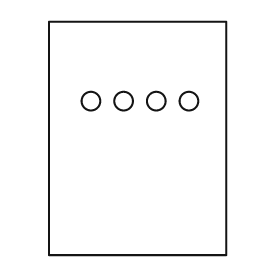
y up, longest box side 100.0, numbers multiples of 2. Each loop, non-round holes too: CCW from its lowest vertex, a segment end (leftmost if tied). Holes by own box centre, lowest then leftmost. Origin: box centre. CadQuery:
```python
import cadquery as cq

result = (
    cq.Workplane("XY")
    .moveTo(-38.0, -50.0)
    .lineTo(38.0, -50.0)
    .lineTo(38.0, 50.0)
    .lineTo(-38.0, 50.0)
    .close()
    .moveTo(-20.0, 16.0)
    .circle(4.0)
    .moveTo(-6.0, 16.0)
    .circle(4.0)
    .moveTo(8.0, 16.0)
    .circle(4.0)
    .moveTo(22.0, 16.0)
    .circle(4.0)
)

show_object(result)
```